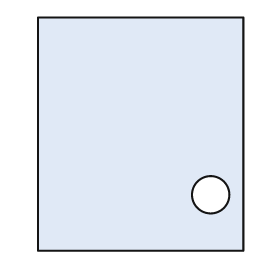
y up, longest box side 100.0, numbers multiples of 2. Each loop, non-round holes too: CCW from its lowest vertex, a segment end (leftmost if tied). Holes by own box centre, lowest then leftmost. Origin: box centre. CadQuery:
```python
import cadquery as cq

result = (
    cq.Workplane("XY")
    .moveTo(-44.0, -50.0)
    .lineTo(44.0, -50.0)
    .lineTo(44.0, 50.0)
    .lineTo(-44.0, 50.0)
    .close()
    .moveTo(30.0, -26.0)
    .circle(8.0)
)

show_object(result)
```